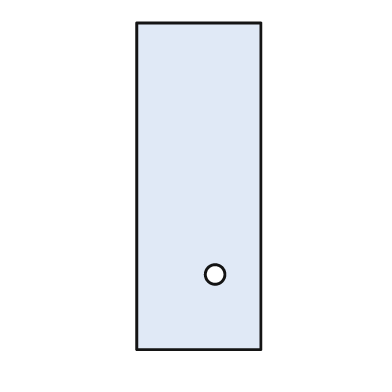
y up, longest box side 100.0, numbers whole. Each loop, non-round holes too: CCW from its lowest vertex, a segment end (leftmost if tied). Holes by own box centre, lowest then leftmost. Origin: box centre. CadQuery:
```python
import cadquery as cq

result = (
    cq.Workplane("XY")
    .moveTo(-19.0, -50.0)
    .lineTo(19.0, -50.0)
    .lineTo(19.0, 50.0)
    .lineTo(-19.0, 50.0)
    .close()
    .moveTo(5.0, -27.0)
    .circle(3.0)
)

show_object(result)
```